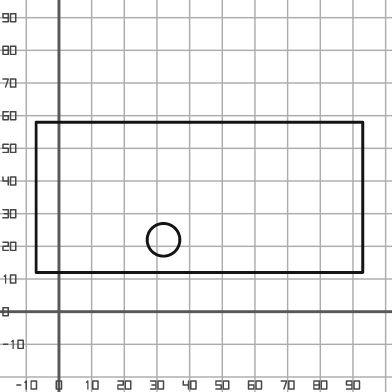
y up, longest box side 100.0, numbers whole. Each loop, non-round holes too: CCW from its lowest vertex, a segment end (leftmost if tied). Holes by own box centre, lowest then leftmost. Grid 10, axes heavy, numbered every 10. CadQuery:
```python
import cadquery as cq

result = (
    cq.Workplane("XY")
    .moveTo(-7.0, 12.0)
    .lineTo(93.0, 12.0)
    .lineTo(93.0, 58.0)
    .lineTo(-7.0, 58.0)
    .close()
    .moveTo(32.0, 22.0)
    .circle(5.0)
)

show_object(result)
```